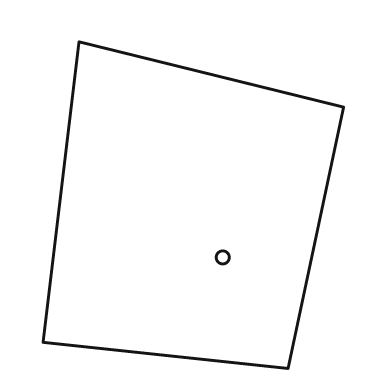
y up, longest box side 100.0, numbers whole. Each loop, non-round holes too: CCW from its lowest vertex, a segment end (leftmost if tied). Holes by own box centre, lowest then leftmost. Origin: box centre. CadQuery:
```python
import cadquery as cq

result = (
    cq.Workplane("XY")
    .moveTo(29.0, -50.0)
    .lineTo(46.0, 30.0)
    .lineTo(-35.0, 50.0)
    .lineTo(-46.0, -42.0)
    .close()
    .moveTo(9.0, -16.0)
    .circle(2.0)
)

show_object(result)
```